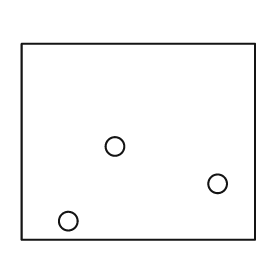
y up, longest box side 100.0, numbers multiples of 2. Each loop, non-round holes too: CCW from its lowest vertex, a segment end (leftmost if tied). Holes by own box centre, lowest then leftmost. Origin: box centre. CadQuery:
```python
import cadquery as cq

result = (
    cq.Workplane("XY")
    .moveTo(-50.0, -42.0)
    .lineTo(50.0, -42.0)
    .lineTo(50.0, 42.0)
    .lineTo(-50.0, 42.0)
    .close()
    .moveTo(-30.0, -34.0)
    .circle(4.0)
    .moveTo(34.0, -18.0)
    .circle(4.0)
    .moveTo(-10.0, -2.0)
    .circle(4.0)
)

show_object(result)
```